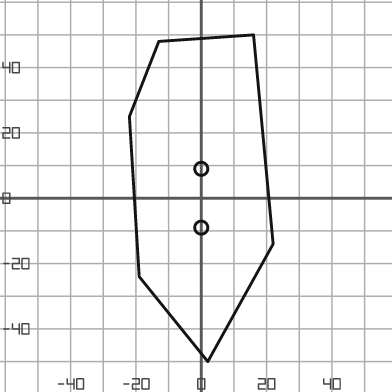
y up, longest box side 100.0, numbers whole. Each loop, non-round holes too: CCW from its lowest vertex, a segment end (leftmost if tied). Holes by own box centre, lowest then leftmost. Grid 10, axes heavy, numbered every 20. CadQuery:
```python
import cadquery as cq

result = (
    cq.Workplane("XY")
    .moveTo(2.0, -50.0)
    .lineTo(22.0, -14.0)
    .lineTo(16.0, 50.0)
    .lineTo(-13.0, 48.0)
    .lineTo(-22.0, 25.0)
    .lineTo(-19.0, -24.0)
    .close()
    .moveTo(0.0, -9.0)
    .circle(2.0)
    .moveTo(0.0, 9.0)
    .circle(2.0)
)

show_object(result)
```